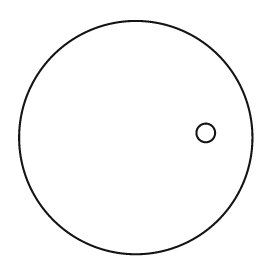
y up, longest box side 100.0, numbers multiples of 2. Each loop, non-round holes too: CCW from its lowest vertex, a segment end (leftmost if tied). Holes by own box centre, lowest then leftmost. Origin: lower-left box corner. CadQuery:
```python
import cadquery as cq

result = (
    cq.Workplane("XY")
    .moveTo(50.0, 50.0)
    .circle(50.0)
    .moveTo(80.0, 52.0)
    .circle(4.0)
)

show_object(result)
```